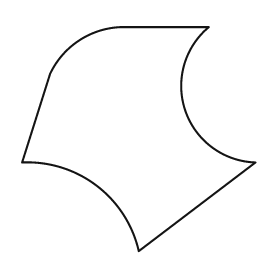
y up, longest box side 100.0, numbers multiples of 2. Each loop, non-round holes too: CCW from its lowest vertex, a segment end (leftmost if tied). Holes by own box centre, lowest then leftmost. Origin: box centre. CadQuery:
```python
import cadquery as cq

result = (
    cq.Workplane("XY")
    .moveTo(0.0, -48.0)
    .lineTo(50.0, -10.0)
    .threePointArc((20.0, 12.0), (30.0, 48.0))
    .lineTo(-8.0, 48.0)
    .threePointArc((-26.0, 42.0), (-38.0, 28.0))
    .lineTo(-50.0, -10.0)
    .threePointArc((-18.0, -20.0), (0.0, -48.0))
    .close()
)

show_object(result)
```